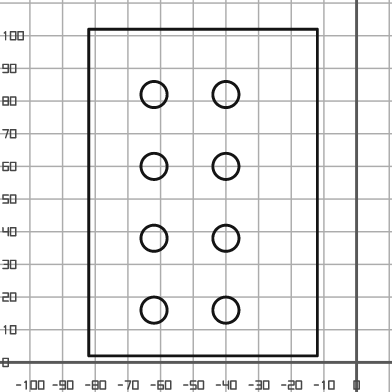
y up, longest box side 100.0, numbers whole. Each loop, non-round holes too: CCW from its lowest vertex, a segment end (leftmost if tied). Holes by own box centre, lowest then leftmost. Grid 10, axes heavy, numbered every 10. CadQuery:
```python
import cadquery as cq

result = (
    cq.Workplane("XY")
    .moveTo(-82.0, 2.0)
    .lineTo(-12.0, 2.0)
    .lineTo(-12.0, 102.0)
    .lineTo(-82.0, 102.0)
    .close()
    .moveTo(-62.0, 16.0)
    .circle(4.0)
    .moveTo(-40.0, 16.0)
    .circle(4.0)
    .moveTo(-62.0, 38.0)
    .circle(4.0)
    .moveTo(-40.0, 38.0)
    .circle(4.0)
    .moveTo(-62.0, 60.0)
    .circle(4.0)
    .moveTo(-40.0, 60.0)
    .circle(4.0)
    .moveTo(-62.0, 82.0)
    .circle(4.0)
    .moveTo(-40.0, 82.0)
    .circle(4.0)
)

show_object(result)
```